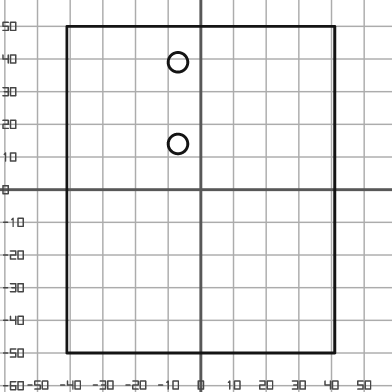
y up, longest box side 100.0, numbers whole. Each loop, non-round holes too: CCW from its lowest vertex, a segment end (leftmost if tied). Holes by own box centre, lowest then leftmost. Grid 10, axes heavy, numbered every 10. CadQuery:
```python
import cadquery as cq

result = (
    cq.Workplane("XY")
    .moveTo(-41.0, -50.0)
    .lineTo(41.0, -50.0)
    .lineTo(41.0, 50.0)
    .lineTo(-41.0, 50.0)
    .close()
    .moveTo(-7.0, 14.0)
    .circle(3.0)
    .moveTo(-7.0, 39.0)
    .circle(3.0)
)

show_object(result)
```